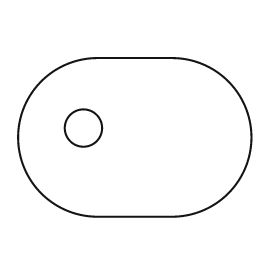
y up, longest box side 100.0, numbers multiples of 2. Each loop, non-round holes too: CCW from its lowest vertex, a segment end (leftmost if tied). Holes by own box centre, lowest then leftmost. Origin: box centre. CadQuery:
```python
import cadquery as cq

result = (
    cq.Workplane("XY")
    .moveTo(-16.0, -34.0)
    .lineTo(16.0, -34.0)
    .threePointArc((50.0, 0.0), (16.0, 34.0))
    .lineTo(-16.0, 34.0)
    .threePointArc((-50.0, 0.0), (-16.0, -34.0))
    .close()
    .moveTo(-22.0, 4.0)
    .circle(8.0)
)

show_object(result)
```